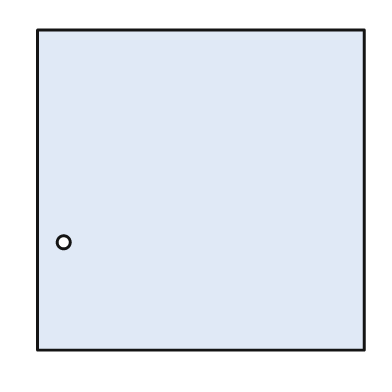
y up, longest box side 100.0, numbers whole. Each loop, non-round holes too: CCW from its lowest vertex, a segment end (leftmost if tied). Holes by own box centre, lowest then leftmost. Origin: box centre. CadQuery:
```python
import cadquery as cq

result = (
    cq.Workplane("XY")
    .moveTo(-50.0, -49.0)
    .lineTo(50.0, -49.0)
    .lineTo(50.0, 49.0)
    .lineTo(-50.0, 49.0)
    .close()
    .moveTo(-42.0, -16.0)
    .circle(2.0)
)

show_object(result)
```